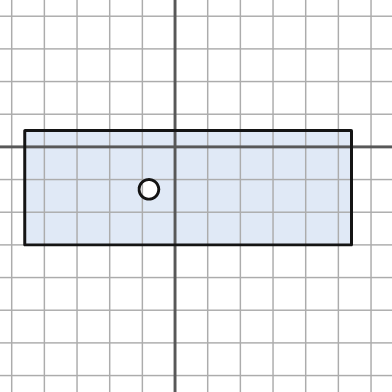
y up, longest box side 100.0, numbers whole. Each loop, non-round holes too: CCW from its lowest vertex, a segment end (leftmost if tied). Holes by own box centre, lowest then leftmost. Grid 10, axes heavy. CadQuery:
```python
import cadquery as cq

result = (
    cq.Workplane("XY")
    .moveTo(-46.0, -30.0)
    .lineTo(54.0, -30.0)
    .lineTo(54.0, 5.0)
    .lineTo(-46.0, 5.0)
    .close()
    .moveTo(-8.0, -13.0)
    .circle(3.0)
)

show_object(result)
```